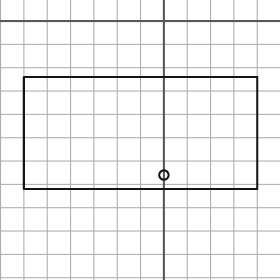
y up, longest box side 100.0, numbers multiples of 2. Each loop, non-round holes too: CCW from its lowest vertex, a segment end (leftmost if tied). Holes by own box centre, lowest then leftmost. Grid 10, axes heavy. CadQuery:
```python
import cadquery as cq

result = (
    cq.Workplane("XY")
    .moveTo(-60.0, -72.0)
    .lineTo(40.0, -72.0)
    .lineTo(40.0, -24.0)
    .lineTo(-60.0, -24.0)
    .close()
    .moveTo(0.0, -66.0)
    .circle(2.0)
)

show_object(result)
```